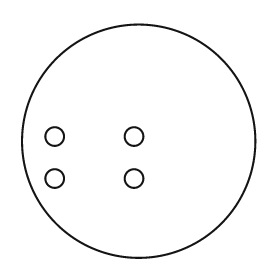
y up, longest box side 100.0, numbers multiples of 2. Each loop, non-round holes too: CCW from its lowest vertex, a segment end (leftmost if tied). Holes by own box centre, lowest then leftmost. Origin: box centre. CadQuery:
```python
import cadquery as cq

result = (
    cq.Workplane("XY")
    .moveTo(0.0, 0.0)
    .circle(50.0)
    .moveTo(-36.0, -16.0)
    .circle(4.0)
    .moveTo(-2.0, -16.0)
    .circle(4.0)
    .moveTo(-36.0, 2.0)
    .circle(4.0)
    .moveTo(-2.0, 2.0)
    .circle(4.0)
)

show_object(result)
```